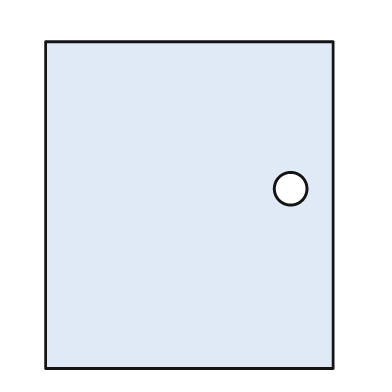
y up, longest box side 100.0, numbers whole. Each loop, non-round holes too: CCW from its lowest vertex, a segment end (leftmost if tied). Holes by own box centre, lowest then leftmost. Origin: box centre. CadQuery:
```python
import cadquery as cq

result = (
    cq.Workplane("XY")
    .moveTo(-44.0, -50.0)
    .lineTo(44.0, -50.0)
    .lineTo(44.0, 50.0)
    .lineTo(-44.0, 50.0)
    .close()
    .moveTo(31.0, 5.0)
    .circle(5.0)
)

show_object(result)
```